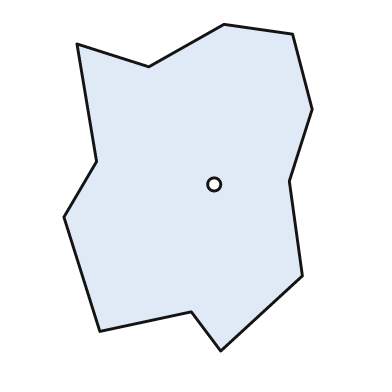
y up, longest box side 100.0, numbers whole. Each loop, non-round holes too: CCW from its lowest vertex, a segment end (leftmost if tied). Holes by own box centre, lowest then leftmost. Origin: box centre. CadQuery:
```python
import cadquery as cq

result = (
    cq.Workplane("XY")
    .moveTo(10.0, -50.0)
    .lineTo(35.0, -27.0)
    .lineTo(31.0, 2.0)
    .lineTo(38.0, 24.0)
    .lineTo(32.0, 47.0)
    .lineTo(11.0, 50.0)
    .lineTo(-12.0, 37.0)
    .lineTo(-34.0, 44.0)
    .lineTo(-28.0, 8.0)
    .lineTo(-38.0, -9.0)
    .lineTo(-27.0, -44.0)
    .lineTo(1.0, -38.0)
    .close()
    .moveTo(8.0, 1.0)
    .circle(2.0)
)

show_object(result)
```